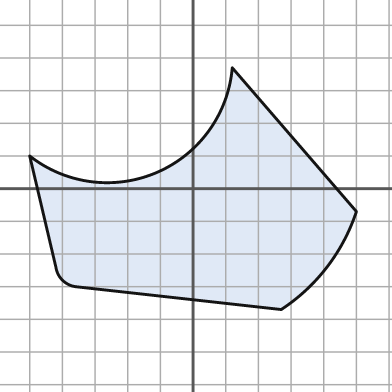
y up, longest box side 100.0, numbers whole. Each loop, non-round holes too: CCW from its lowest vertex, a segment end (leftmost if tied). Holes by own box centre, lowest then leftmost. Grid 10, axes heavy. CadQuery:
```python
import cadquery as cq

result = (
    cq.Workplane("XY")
    .moveTo(27.0, -37.0)
    .threePointArc((41.0, -24.0), (50.0, -7.0))
    .lineTo(12.0, 37.0)
    .threePointArc((-11.0, 5.0), (-50.0, 10.0))
    .lineTo(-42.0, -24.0)
    .threePointArc((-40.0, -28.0), (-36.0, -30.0))
    .close()
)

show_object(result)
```